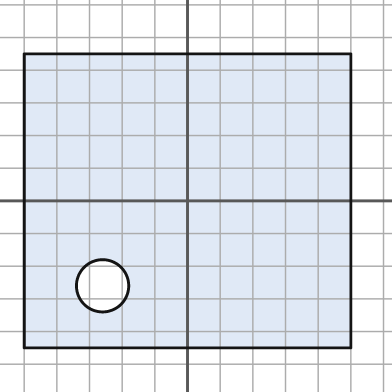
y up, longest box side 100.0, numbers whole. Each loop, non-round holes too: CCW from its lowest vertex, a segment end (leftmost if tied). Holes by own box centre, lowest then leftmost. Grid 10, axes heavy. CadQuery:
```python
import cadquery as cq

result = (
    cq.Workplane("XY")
    .moveTo(-50.0, -45.0)
    .lineTo(50.0, -45.0)
    .lineTo(50.0, 45.0)
    .lineTo(-50.0, 45.0)
    .close()
    .moveTo(-26.0, -26.0)
    .circle(8.0)
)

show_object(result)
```